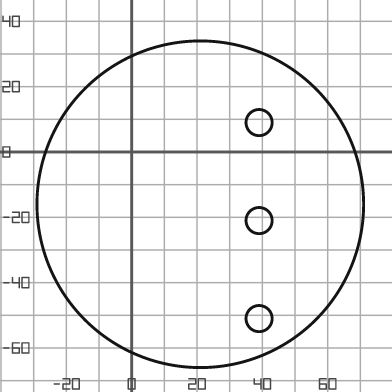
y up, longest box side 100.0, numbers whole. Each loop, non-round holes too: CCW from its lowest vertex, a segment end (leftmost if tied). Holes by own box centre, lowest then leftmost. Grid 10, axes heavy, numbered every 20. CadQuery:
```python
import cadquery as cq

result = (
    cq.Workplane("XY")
    .moveTo(21.0, -16.0)
    .circle(50.0)
    .moveTo(39.0, -51.0)
    .circle(4.0)
    .moveTo(39.0, -21.0)
    .circle(4.0)
    .moveTo(39.0, 9.0)
    .circle(4.0)
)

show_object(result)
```